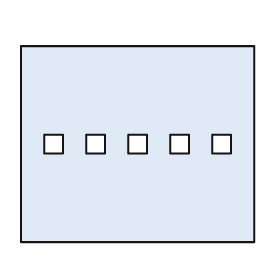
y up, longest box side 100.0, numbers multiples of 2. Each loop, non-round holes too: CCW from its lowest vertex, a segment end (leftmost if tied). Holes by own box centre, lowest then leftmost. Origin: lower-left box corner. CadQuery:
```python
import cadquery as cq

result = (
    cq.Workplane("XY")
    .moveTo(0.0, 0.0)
    .lineTo(100.0, 0.0)
    .lineTo(100.0, 84.0)
    .lineTo(0.0, 84.0)
    .close()
    .moveTo(10.0, 38.0)
    .lineTo(18.0, 38.0)
    .lineTo(18.0, 46.0)
    .lineTo(10.0, 46.0)
    .close()
    .moveTo(28.0, 38.0)
    .lineTo(36.0, 38.0)
    .lineTo(36.0, 46.0)
    .lineTo(28.0, 46.0)
    .close()
    .moveTo(46.0, 38.0)
    .lineTo(54.0, 38.0)
    .lineTo(54.0, 46.0)
    .lineTo(46.0, 46.0)
    .close()
    .moveTo(64.0, 38.0)
    .lineTo(72.0, 38.0)
    .lineTo(72.0, 46.0)
    .lineTo(64.0, 46.0)
    .close()
    .moveTo(82.0, 38.0)
    .lineTo(90.0, 38.0)
    .lineTo(90.0, 46.0)
    .lineTo(82.0, 46.0)
    .close()
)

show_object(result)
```